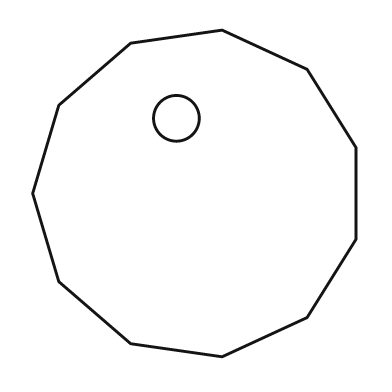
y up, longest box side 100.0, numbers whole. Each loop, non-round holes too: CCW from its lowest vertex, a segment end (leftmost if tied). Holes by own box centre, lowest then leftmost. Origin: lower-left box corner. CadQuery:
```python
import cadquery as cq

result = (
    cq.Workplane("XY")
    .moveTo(58.0, 0.0)
    .lineTo(84.0, 12.0)
    .lineTo(99.0, 36.0)
    .lineTo(99.0, 64.0)
    .lineTo(84.0, 88.0)
    .lineTo(58.0, 100.0)
    .lineTo(30.0, 96.0)
    .lineTo(8.0, 77.0)
    .lineTo(0.0, 50.0)
    .lineTo(8.0, 23.0)
    .lineTo(30.0, 4.0)
    .close()
    .moveTo(44.0, 73.0)
    .circle(7.0)
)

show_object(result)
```